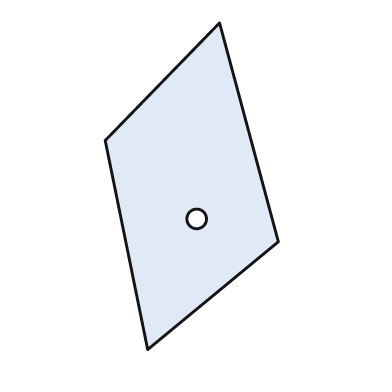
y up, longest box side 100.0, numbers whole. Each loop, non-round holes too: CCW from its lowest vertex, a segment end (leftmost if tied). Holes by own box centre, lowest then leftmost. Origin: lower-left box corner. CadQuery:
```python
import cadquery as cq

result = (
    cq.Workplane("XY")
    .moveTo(13.0, 0.0)
    .lineTo(53.0, 33.0)
    .lineTo(35.0, 100.0)
    .lineTo(0.0, 64.0)
    .close()
    .moveTo(28.0, 40.0)
    .circle(3.0)
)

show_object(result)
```